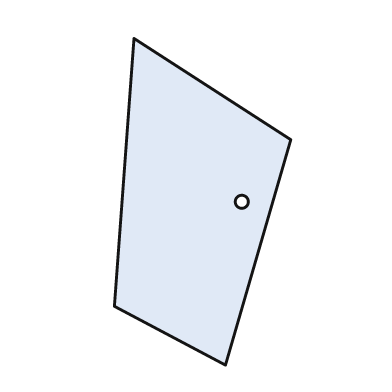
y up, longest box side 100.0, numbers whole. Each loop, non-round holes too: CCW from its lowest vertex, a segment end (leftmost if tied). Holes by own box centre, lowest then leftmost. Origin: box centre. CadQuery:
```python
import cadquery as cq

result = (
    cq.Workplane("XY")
    .moveTo(7.0, -50.0)
    .lineTo(27.0, 19.0)
    .lineTo(-21.0, 50.0)
    .lineTo(-27.0, -32.0)
    .close()
    .moveTo(12.0, 0.0)
    .circle(2.0)
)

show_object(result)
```